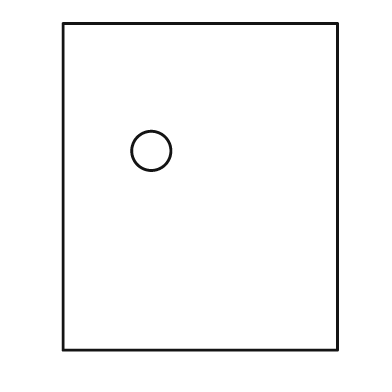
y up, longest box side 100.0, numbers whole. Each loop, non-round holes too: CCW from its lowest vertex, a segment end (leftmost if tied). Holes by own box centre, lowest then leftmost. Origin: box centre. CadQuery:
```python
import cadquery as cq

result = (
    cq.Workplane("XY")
    .moveTo(-42.0, -50.0)
    .lineTo(42.0, -50.0)
    .lineTo(42.0, 50.0)
    .lineTo(-42.0, 50.0)
    .close()
    .moveTo(-15.0, 11.0)
    .circle(6.0)
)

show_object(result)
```